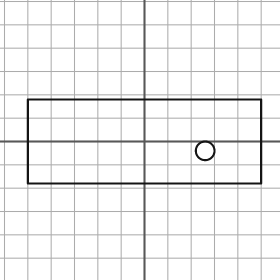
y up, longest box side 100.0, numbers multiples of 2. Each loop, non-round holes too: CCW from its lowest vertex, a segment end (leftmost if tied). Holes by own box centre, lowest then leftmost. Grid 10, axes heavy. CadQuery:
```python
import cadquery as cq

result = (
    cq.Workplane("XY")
    .moveTo(-50.0, -18.0)
    .lineTo(50.0, -18.0)
    .lineTo(50.0, 18.0)
    .lineTo(-50.0, 18.0)
    .close()
    .moveTo(26.0, -4.0)
    .circle(4.0)
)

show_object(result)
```